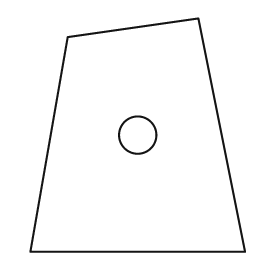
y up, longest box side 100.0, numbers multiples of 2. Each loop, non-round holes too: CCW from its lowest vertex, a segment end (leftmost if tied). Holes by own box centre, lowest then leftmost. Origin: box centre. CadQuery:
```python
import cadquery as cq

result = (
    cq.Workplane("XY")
    .moveTo(-46.0, -50.0)
    .lineTo(46.0, -50.0)
    .lineTo(26.0, 50.0)
    .lineTo(-30.0, 42.0)
    .close()
    .moveTo(0.0, 0.0)
    .circle(8.0)
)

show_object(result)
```